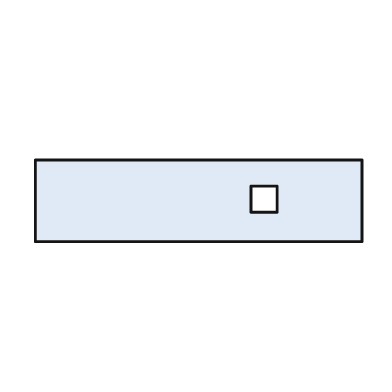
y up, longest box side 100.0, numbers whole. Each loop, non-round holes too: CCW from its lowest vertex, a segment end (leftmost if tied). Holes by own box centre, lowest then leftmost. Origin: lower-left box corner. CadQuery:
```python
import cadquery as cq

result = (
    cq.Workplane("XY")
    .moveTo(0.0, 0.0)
    .lineTo(100.0, 0.0)
    .lineTo(100.0, 25.0)
    .lineTo(0.0, 25.0)
    .close()
    .moveTo(66.0, 9.0)
    .lineTo(74.0, 9.0)
    .lineTo(74.0, 17.0)
    .lineTo(66.0, 17.0)
    .close()
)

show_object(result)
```